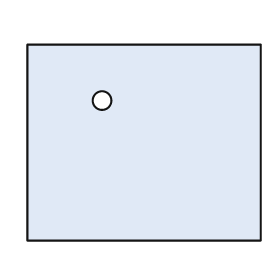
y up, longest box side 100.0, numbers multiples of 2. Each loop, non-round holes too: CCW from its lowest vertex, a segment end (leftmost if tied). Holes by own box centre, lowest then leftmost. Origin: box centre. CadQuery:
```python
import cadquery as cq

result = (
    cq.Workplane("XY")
    .moveTo(-50.0, -42.0)
    .lineTo(50.0, -42.0)
    .lineTo(50.0, 42.0)
    .lineTo(-50.0, 42.0)
    .close()
    .moveTo(-18.0, 18.0)
    .circle(4.0)
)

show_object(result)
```